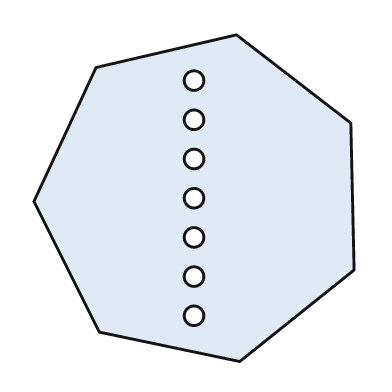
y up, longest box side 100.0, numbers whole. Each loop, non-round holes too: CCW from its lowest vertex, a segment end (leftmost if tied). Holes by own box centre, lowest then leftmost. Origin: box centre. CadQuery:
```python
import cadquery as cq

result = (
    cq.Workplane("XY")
    .moveTo(14.0, -50.0)
    .lineTo(49.0, -22.0)
    .lineTo(48.0, 23.0)
    .lineTo(13.0, 50.0)
    .lineTo(-30.0, 40.0)
    .lineTo(-49.0, -1.0)
    .lineTo(-29.0, -41.0)
    .close()
    .moveTo(0.0, -36.0)
    .circle(3.0)
    .moveTo(0.0, -24.0)
    .circle(3.0)
    .moveTo(0.0, -12.0)
    .circle(3.0)
    .moveTo(0.0, 0.0)
    .circle(3.0)
    .moveTo(0.0, 12.0)
    .circle(3.0)
    .moveTo(0.0, 24.0)
    .circle(3.0)
    .moveTo(0.0, 36.0)
    .circle(3.0)
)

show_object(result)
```